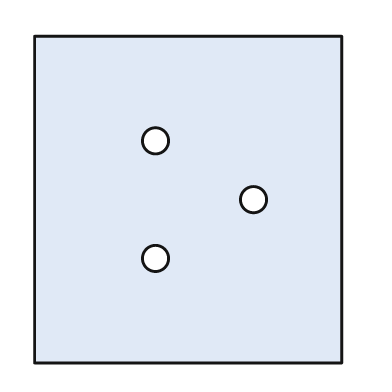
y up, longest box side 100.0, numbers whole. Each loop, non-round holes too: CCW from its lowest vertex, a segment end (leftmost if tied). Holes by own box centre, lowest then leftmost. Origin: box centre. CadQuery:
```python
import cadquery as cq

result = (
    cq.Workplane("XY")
    .moveTo(-47.0, -50.0)
    .lineTo(47.0, -50.0)
    .lineTo(47.0, 50.0)
    .lineTo(-47.0, 50.0)
    .close()
    .moveTo(-10.0, -18.0)
    .circle(4.0)
    .moveTo(20.0, 0.0)
    .circle(4.0)
    .moveTo(-10.0, 18.0)
    .circle(4.0)
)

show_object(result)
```